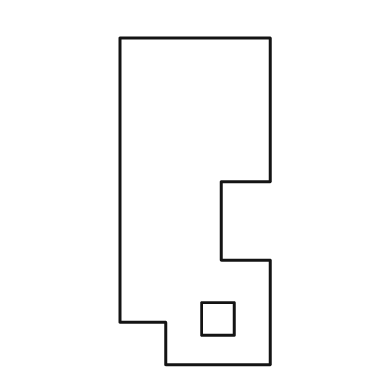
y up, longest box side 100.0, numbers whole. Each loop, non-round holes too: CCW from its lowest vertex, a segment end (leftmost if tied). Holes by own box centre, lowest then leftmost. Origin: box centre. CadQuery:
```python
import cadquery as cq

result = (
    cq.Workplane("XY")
    .moveTo(-9.0, -50.0)
    .lineTo(23.0, -50.0)
    .lineTo(23.0, -18.0)
    .lineTo(8.0, -18.0)
    .lineTo(8.0, 6.0)
    .lineTo(23.0, 6.0)
    .lineTo(23.0, 50.0)
    .lineTo(-23.0, 50.0)
    .lineTo(-23.0, -37.0)
    .lineTo(-9.0, -37.0)
    .close()
    .moveTo(2.0, -41.0)
    .lineTo(12.0, -41.0)
    .lineTo(12.0, -31.0)
    .lineTo(2.0, -31.0)
    .close()
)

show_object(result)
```